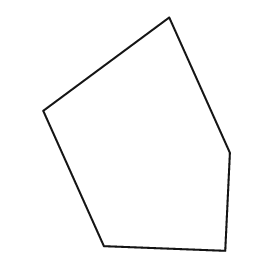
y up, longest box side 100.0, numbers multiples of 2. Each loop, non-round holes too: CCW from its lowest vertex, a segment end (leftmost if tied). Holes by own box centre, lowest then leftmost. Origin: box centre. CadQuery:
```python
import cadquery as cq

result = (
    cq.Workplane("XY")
    .moveTo(38.0, -50.0)
    .lineTo(40.0, -8.0)
    .lineTo(14.0, 50.0)
    .lineTo(-40.0, 10.0)
    .lineTo(-14.0, -48.0)
    .close()
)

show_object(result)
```